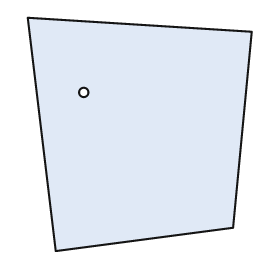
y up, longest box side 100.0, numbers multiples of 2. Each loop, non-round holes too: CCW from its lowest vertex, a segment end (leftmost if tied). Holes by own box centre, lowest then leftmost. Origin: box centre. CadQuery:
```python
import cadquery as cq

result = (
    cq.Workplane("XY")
    .moveTo(-36.0, -50.0)
    .lineTo(40.0, -40.0)
    .lineTo(48.0, 44.0)
    .lineTo(-48.0, 50.0)
    .close()
    .moveTo(-24.0, 18.0)
    .circle(2.0)
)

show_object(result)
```